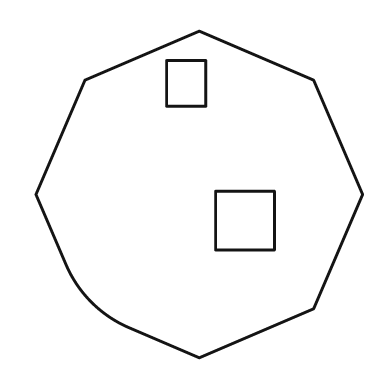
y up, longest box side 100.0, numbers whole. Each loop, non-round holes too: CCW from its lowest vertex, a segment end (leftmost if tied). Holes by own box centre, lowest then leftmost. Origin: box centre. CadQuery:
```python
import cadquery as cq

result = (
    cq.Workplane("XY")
    .moveTo(0.0, -50.0)
    .lineTo(35.0, -35.0)
    .lineTo(50.0, 0.0)
    .lineTo(35.0, 35.0)
    .lineTo(0.0, 50.0)
    .lineTo(-35.0, 35.0)
    .lineTo(-50.0, 0.0)
    .lineTo(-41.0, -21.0)
    .threePointArc((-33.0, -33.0), (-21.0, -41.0))
    .close()
    .moveTo(5.0, -17.0)
    .lineTo(23.0, -17.0)
    .lineTo(23.0, 1.0)
    .lineTo(5.0, 1.0)
    .close()
    .moveTo(-10.0, 27.0)
    .lineTo(2.0, 27.0)
    .lineTo(2.0, 41.0)
    .lineTo(-10.0, 41.0)
    .close()
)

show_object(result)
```